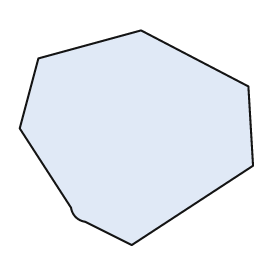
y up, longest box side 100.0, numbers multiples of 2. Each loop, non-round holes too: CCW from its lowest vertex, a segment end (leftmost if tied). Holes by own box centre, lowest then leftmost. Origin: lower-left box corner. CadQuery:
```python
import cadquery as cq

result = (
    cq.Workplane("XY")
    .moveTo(48.0, 0.0)
    .lineTo(100.0, 34.0)
    .lineTo(98.0, 68.0)
    .lineTo(52.0, 92.0)
    .lineTo(8.0, 80.0)
    .lineTo(0.0, 50.0)
    .lineTo(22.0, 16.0)
    .threePointArc((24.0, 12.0), (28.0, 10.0))
    .close()
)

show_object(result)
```